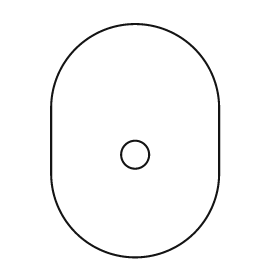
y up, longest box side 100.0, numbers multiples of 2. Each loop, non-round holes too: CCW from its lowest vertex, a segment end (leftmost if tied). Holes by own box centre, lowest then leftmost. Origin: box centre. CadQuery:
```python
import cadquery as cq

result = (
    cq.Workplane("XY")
    .moveTo(-36.0, -14.0)
    .threePointArc((0.0, -50.0), (36.0, -14.0))
    .lineTo(36.0, 14.0)
    .threePointArc((0.0, 50.0), (-36.0, 14.0))
    .close()
    .moveTo(0.0, -6.0)
    .circle(6.0)
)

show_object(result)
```